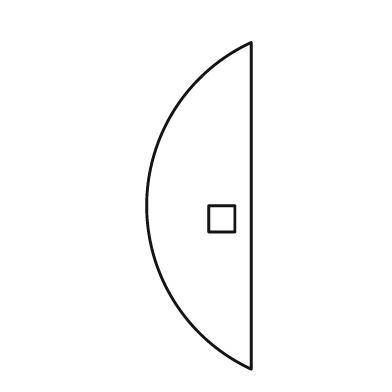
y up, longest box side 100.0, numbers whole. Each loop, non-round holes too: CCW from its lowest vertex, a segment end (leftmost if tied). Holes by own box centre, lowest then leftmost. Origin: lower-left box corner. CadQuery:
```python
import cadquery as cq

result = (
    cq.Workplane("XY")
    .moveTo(32.0, 0.0)
    .lineTo(32.0, 100.0)
    .threePointArc((0.0, 50.0), (32.0, 0.0))
    .close()
    .moveTo(19.0, 42.0)
    .lineTo(27.0, 42.0)
    .lineTo(27.0, 50.0)
    .lineTo(19.0, 50.0)
    .close()
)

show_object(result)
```